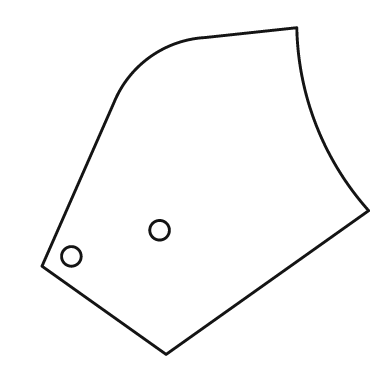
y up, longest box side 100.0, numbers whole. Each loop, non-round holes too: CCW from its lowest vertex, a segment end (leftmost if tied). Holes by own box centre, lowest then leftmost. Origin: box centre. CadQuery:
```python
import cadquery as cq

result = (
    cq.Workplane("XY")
    .moveTo(-12.0, -50.0)
    .lineTo(50.0, -6.0)
    .threePointArc((34.0, 20.0), (28.0, 50.0))
    .lineTo(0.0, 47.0)
    .threePointArc((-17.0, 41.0), (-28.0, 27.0))
    .lineTo(-50.0, -23.0)
    .close()
    .moveTo(-41.0, -20.0)
    .circle(3.0)
    .moveTo(-14.0, -12.0)
    .circle(3.0)
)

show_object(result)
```